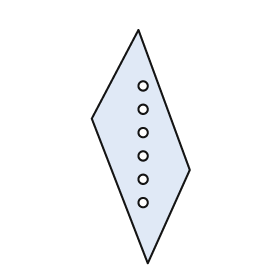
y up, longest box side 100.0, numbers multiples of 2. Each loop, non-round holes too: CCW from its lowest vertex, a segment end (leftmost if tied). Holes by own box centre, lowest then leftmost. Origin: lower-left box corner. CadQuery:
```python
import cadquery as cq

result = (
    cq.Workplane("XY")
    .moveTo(24.0, 0.0)
    .lineTo(42.0, 40.0)
    .lineTo(20.0, 100.0)
    .lineTo(0.0, 62.0)
    .close()
    .moveTo(22.0, 26.0)
    .circle(2.0)
    .moveTo(22.0, 36.0)
    .circle(2.0)
    .moveTo(22.0, 46.0)
    .circle(2.0)
    .moveTo(22.0, 56.0)
    .circle(2.0)
    .moveTo(22.0, 66.0)
    .circle(2.0)
    .moveTo(22.0, 76.0)
    .circle(2.0)
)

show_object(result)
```